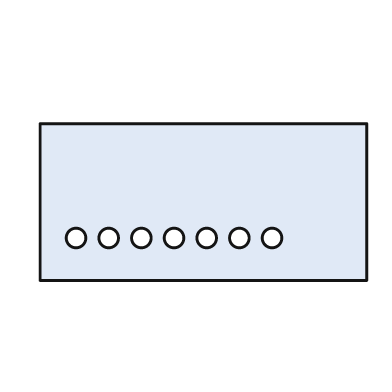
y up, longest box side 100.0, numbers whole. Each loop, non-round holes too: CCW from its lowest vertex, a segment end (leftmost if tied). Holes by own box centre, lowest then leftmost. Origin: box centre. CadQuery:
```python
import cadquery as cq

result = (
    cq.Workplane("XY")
    .moveTo(-50.0, -24.0)
    .lineTo(50.0, -24.0)
    .lineTo(50.0, 24.0)
    .lineTo(-50.0, 24.0)
    .close()
    .moveTo(-39.0, -11.0)
    .circle(3.0)
    .moveTo(-29.0, -11.0)
    .circle(3.0)
    .moveTo(-19.0, -11.0)
    .circle(3.0)
    .moveTo(-9.0, -11.0)
    .circle(3.0)
    .moveTo(1.0, -11.0)
    .circle(3.0)
    .moveTo(11.0, -11.0)
    .circle(3.0)
    .moveTo(21.0, -11.0)
    .circle(3.0)
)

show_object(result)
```